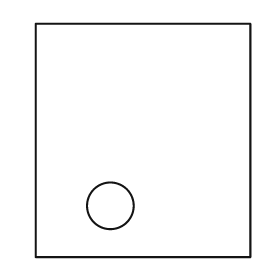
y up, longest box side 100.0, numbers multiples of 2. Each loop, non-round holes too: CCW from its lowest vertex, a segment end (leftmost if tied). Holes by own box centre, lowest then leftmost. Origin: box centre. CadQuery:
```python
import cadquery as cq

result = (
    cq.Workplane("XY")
    .moveTo(-46.0, -50.0)
    .lineTo(46.0, -50.0)
    .lineTo(46.0, 50.0)
    .lineTo(-46.0, 50.0)
    .close()
    .moveTo(-14.0, -28.0)
    .circle(10.0)
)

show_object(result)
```